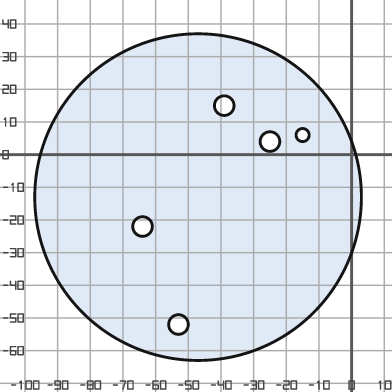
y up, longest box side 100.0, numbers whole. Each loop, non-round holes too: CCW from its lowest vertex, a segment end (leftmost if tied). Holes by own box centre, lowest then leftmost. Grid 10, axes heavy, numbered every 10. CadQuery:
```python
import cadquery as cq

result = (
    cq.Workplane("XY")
    .moveTo(-47.0, -13.0)
    .circle(50.0)
    .moveTo(-53.0, -52.0)
    .circle(3.0)
    .moveTo(-64.0, -22.0)
    .circle(3.0)
    .moveTo(-25.0, 4.0)
    .circle(3.0)
    .moveTo(-15.0, 6.0)
    .circle(2.0)
    .moveTo(-39.0, 15.0)
    .circle(3.0)
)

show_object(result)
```